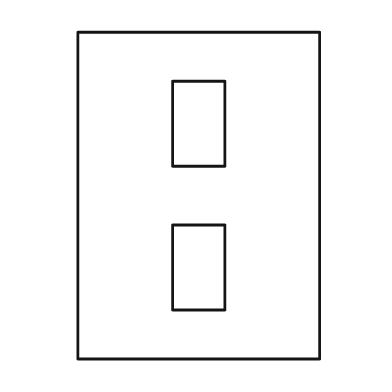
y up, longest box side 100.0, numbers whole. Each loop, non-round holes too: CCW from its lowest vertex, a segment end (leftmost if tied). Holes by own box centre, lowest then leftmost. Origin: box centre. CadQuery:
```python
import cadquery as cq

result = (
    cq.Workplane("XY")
    .moveTo(-37.0, -50.0)
    .lineTo(37.0, -50.0)
    .lineTo(37.0, 50.0)
    .lineTo(-37.0, 50.0)
    .close()
    .moveTo(-8.0, -35.0)
    .lineTo(8.0, -35.0)
    .lineTo(8.0, -9.0)
    .lineTo(-8.0, -9.0)
    .close()
    .moveTo(-8.0, 9.0)
    .lineTo(8.0, 9.0)
    .lineTo(8.0, 35.0)
    .lineTo(-8.0, 35.0)
    .close()
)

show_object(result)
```